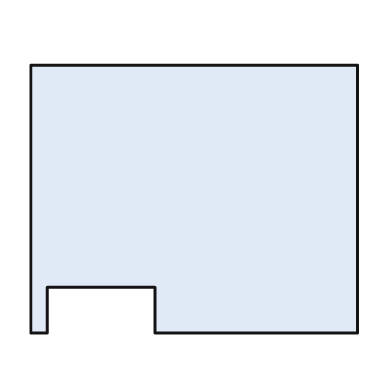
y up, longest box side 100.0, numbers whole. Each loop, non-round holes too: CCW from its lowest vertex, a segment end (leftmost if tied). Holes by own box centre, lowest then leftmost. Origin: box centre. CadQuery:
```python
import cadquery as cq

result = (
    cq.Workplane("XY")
    .moveTo(-50.0, -41.0)
    .lineTo(-45.0, -41.0)
    .lineTo(-45.0, -27.0)
    .lineTo(-12.0, -27.0)
    .lineTo(-12.0, -41.0)
    .lineTo(50.0, -41.0)
    .lineTo(50.0, 41.0)
    .lineTo(-50.0, 41.0)
    .close()
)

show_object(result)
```